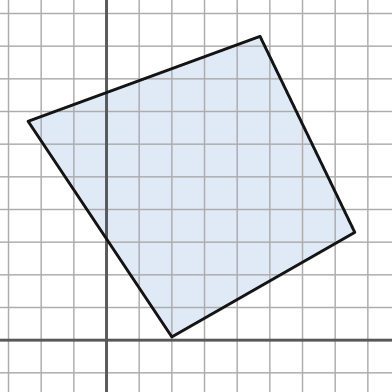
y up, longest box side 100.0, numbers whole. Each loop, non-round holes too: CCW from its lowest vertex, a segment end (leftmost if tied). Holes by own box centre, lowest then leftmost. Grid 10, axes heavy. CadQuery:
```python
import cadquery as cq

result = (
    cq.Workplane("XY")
    .moveTo(20.0, 1.0)
    .lineTo(76.0, 33.0)
    .lineTo(47.0, 93.0)
    .lineTo(-24.0, 67.0)
    .close()
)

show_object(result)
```